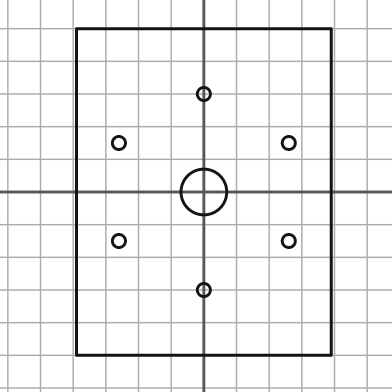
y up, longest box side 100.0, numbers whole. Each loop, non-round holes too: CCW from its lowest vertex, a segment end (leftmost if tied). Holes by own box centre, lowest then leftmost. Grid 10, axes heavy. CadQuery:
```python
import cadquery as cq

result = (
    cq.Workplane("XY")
    .moveTo(-39.0, -50.0)
    .lineTo(39.0, -50.0)
    .lineTo(39.0, 50.0)
    .lineTo(-39.0, 50.0)
    .close()
    .moveTo(0.0, -30.0)
    .circle(2.0)
    .moveTo(-26.0, -15.0)
    .circle(2.0)
    .moveTo(26.0, -15.0)
    .circle(2.0)
    .moveTo(0.0, 0.0)
    .circle(7.0)
    .moveTo(-26.0, 15.0)
    .circle(2.0)
    .moveTo(26.0, 15.0)
    .circle(2.0)
    .moveTo(0.0, 30.0)
    .circle(2.0)
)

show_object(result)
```